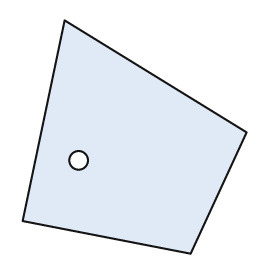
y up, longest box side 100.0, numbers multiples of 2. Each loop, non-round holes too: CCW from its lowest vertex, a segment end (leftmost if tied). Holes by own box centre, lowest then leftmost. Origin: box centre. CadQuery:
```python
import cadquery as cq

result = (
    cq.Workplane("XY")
    .moveTo(24.0, -50.0)
    .lineTo(48.0, 2.0)
    .lineTo(-30.0, 50.0)
    .lineTo(-48.0, -36.0)
    .close()
    .moveTo(-24.0, -10.0)
    .circle(4.0)
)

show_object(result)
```